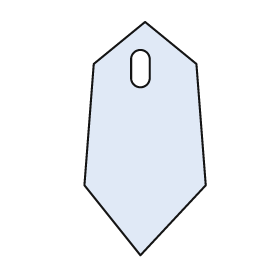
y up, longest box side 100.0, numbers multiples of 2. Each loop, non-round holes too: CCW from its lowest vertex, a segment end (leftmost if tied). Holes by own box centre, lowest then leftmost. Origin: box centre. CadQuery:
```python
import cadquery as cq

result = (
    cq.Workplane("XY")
    .moveTo(-2.0, -50.0)
    .lineTo(26.0, -20.0)
    .lineTo(22.0, 32.0)
    .lineTo(0.0, 50.0)
    .lineTo(-22.0, 32.0)
    .lineTo(-26.0, -20.0)
    .close()
    .moveTo(-6.0, 26.0)
    .threePointArc((-2.0, 22.0), (2.0, 26.0))
    .lineTo(2.0, 34.0)
    .threePointArc((-2.0, 38.0), (-6.0, 34.0))
    .close()
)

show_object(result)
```